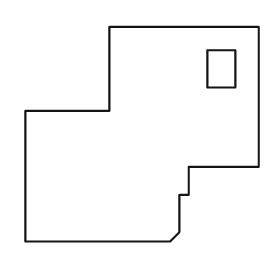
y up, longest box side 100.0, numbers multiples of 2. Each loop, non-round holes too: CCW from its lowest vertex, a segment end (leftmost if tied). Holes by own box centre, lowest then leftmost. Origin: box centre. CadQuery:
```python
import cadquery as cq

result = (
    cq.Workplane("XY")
    .moveTo(-50.0, -46.0)
    .lineTo(12.0, -46.0)
    .lineTo(16.0, -42.0)
    .lineTo(16.0, -26.0)
    .lineTo(20.0, -26.0)
    .lineTo(20.0, -14.0)
    .lineTo(50.0, -14.0)
    .lineTo(50.0, 46.0)
    .lineTo(-14.0, 46.0)
    .lineTo(-14.0, 10.0)
    .lineTo(-50.0, 10.0)
    .close()
    .moveTo(28.0, 20.0)
    .lineTo(40.0, 20.0)
    .lineTo(40.0, 36.0)
    .lineTo(28.0, 36.0)
    .close()
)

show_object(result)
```